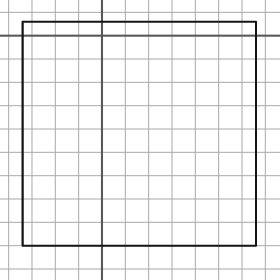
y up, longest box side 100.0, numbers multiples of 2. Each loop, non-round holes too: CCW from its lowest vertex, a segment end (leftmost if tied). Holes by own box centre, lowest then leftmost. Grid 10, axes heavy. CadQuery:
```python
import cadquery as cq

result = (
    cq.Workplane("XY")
    .moveTo(-34.0, -90.0)
    .lineTo(66.0, -90.0)
    .lineTo(66.0, 6.0)
    .lineTo(-34.0, 6.0)
    .close()
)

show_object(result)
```